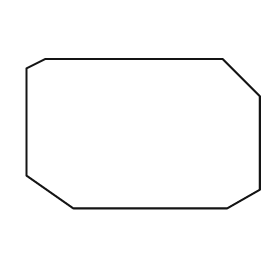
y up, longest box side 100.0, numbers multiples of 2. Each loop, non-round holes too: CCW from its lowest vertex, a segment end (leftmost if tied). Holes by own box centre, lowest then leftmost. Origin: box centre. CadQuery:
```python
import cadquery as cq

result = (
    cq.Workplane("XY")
    .moveTo(-30.0, -32.0)
    .lineTo(36.0, -32.0)
    .lineTo(50.0, -24.0)
    .lineTo(50.0, 16.0)
    .lineTo(34.0, 32.0)
    .lineTo(-42.0, 32.0)
    .lineTo(-50.0, 28.0)
    .lineTo(-50.0, -18.0)
    .close()
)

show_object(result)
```